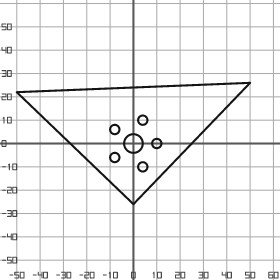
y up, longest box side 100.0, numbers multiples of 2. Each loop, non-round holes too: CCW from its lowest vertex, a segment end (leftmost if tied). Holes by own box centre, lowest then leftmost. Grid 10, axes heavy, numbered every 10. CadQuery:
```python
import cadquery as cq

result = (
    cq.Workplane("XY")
    .moveTo(0.0, -26.0)
    .lineTo(50.0, 26.0)
    .lineTo(-50.0, 22.0)
    .close()
    .moveTo(4.0, -10.0)
    .circle(2.0)
    .moveTo(-8.0, -6.0)
    .circle(2.0)
    .moveTo(0.0, 0.0)
    .circle(4.0)
    .moveTo(10.0, 0.0)
    .circle(2.0)
    .moveTo(-8.0, 6.0)
    .circle(2.0)
    .moveTo(4.0, 10.0)
    .circle(2.0)
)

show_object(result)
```